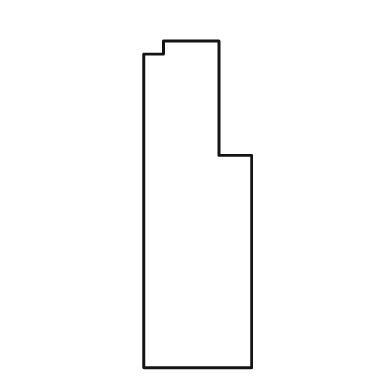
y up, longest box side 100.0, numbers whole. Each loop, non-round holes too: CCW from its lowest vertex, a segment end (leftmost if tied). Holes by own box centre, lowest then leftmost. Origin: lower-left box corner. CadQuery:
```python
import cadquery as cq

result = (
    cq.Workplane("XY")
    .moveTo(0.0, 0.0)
    .lineTo(33.0, 0.0)
    .lineTo(33.0, 65.0)
    .lineTo(23.0, 65.0)
    .lineTo(23.0, 100.0)
    .lineTo(6.0, 100.0)
    .lineTo(6.0, 96.0)
    .lineTo(0.0, 96.0)
    .close()
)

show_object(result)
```